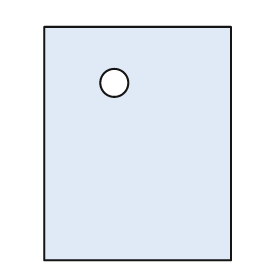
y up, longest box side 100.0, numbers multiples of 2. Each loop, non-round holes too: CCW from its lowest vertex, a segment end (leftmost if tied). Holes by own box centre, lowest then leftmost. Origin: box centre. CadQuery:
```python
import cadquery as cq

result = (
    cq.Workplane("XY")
    .moveTo(-40.0, -50.0)
    .lineTo(40.0, -50.0)
    .lineTo(40.0, 50.0)
    .lineTo(-40.0, 50.0)
    .close()
    .moveTo(-10.0, 26.0)
    .circle(6.0)
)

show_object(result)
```